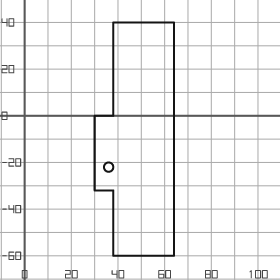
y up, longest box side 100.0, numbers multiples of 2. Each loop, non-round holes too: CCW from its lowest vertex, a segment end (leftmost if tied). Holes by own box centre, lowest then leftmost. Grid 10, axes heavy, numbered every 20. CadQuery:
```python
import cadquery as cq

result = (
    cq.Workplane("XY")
    .moveTo(38.0, -60.0)
    .lineTo(64.0, -60.0)
    .lineTo(64.0, 40.0)
    .lineTo(38.0, 40.0)
    .lineTo(38.0, 0.0)
    .lineTo(30.0, 0.0)
    .lineTo(30.0, -32.0)
    .lineTo(38.0, -32.0)
    .close()
    .moveTo(36.0, -22.0)
    .circle(2.0)
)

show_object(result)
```